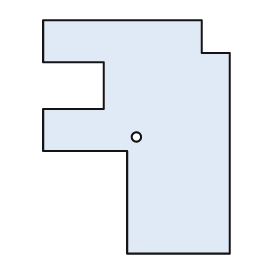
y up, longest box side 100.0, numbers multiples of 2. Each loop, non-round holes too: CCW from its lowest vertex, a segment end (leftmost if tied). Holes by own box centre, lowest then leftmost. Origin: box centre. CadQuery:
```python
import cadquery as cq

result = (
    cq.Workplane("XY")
    .moveTo(-4.0, -50.0)
    .lineTo(40.0, -50.0)
    .lineTo(40.0, 36.0)
    .lineTo(28.0, 36.0)
    .lineTo(28.0, 50.0)
    .lineTo(-40.0, 50.0)
    .lineTo(-40.0, 32.0)
    .lineTo(-14.0, 32.0)
    .lineTo(-14.0, 12.0)
    .lineTo(-40.0, 12.0)
    .lineTo(-40.0, -6.0)
    .lineTo(-4.0, -6.0)
    .close()
    .moveTo(0.0, 0.0)
    .circle(2.0)
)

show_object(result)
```